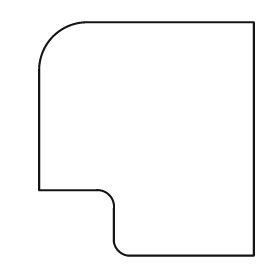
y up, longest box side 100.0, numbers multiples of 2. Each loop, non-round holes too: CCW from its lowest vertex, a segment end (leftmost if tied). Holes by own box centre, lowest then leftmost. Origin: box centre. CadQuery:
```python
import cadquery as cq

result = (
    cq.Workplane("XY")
    .moveTo(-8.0, -50.0)
    .lineTo(46.0, -50.0)
    .lineTo(46.0, 50.0)
    .lineTo(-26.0, 50.0)
    .threePointArc((-40.0, 44.0), (-46.0, 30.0))
    .lineTo(-46.0, -22.0)
    .lineTo(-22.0, -22.0)
    .threePointArc((-16.0, -24.0), (-14.0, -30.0))
    .lineTo(-14.0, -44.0)
    .threePointArc((-12.0, -48.0), (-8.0, -50.0))
    .close()
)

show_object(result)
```